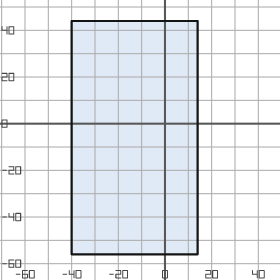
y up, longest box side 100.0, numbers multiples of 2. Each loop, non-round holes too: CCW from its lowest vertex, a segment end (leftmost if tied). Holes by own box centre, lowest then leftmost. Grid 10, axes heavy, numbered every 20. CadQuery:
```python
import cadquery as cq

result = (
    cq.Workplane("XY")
    .moveTo(-40.0, -56.0)
    .lineTo(14.0, -56.0)
    .lineTo(14.0, 44.0)
    .lineTo(-40.0, 44.0)
    .close()
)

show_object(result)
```